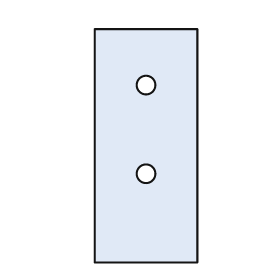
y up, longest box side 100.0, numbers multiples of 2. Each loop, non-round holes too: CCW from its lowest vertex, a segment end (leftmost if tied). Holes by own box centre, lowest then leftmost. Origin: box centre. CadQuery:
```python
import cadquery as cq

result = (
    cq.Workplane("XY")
    .moveTo(-22.0, -50.0)
    .lineTo(22.0, -50.0)
    .lineTo(22.0, 50.0)
    .lineTo(-22.0, 50.0)
    .close()
    .moveTo(0.0, -12.0)
    .circle(4.0)
    .moveTo(0.0, 26.0)
    .circle(4.0)
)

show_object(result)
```